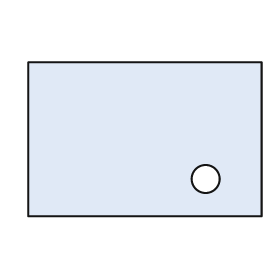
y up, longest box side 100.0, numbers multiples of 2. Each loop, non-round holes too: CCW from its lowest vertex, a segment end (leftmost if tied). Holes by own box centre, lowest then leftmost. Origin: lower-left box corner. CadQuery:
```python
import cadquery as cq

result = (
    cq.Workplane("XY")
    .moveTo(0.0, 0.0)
    .lineTo(100.0, 0.0)
    .lineTo(100.0, 66.0)
    .lineTo(0.0, 66.0)
    .close()
    .moveTo(76.0, 16.0)
    .circle(6.0)
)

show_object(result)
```